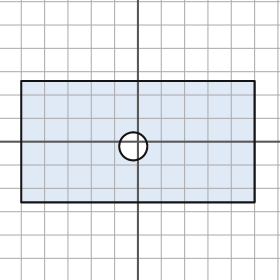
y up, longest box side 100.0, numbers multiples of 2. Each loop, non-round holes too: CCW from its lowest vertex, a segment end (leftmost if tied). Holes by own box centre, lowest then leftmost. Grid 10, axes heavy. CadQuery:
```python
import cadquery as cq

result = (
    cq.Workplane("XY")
    .moveTo(-50.0, -26.0)
    .lineTo(50.0, -26.0)
    .lineTo(50.0, 26.0)
    .lineTo(-50.0, 26.0)
    .close()
    .moveTo(-2.0, -2.0)
    .circle(6.0)
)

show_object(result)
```